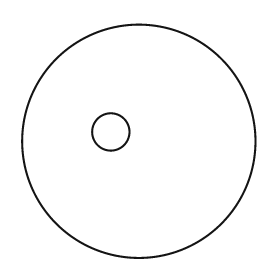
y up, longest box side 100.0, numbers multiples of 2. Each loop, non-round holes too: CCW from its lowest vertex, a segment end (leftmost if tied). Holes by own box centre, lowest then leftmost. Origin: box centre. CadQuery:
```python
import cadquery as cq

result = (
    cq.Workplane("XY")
    .moveTo(0.0, 0.0)
    .circle(50.0)
    .moveTo(-12.0, 4.0)
    .circle(8.0)
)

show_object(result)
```